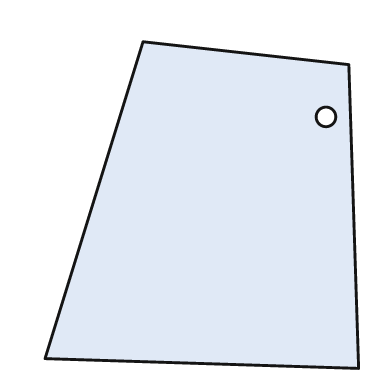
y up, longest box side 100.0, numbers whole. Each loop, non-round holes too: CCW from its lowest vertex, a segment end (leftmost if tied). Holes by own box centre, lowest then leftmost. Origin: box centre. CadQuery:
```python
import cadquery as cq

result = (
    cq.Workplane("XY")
    .moveTo(48.0, -50.0)
    .lineTo(45.0, 43.0)
    .lineTo(-18.0, 50.0)
    .lineTo(-48.0, -47.0)
    .close()
    .moveTo(38.0, 27.0)
    .circle(3.0)
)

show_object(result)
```